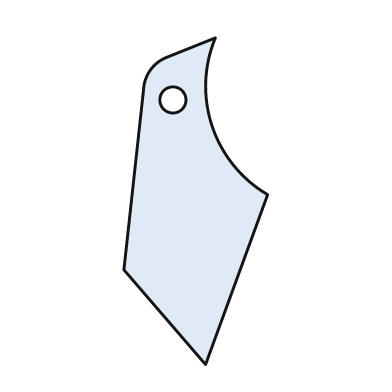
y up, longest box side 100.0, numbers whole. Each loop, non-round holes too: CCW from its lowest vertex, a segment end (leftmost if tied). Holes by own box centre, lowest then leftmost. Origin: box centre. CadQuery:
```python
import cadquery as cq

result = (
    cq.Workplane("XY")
    .moveTo(3.0, -50.0)
    .lineTo(22.0, 2.0)
    .threePointArc((5.0, 23.0), (6.0, 50.0))
    .lineTo(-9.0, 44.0)
    .threePointArc((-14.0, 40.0), (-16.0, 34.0))
    .lineTo(-22.0, -21.0)
    .close()
    .moveTo(-7.0, 31.0)
    .circle(4.0)
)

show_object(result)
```